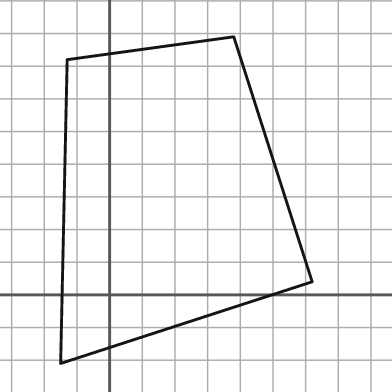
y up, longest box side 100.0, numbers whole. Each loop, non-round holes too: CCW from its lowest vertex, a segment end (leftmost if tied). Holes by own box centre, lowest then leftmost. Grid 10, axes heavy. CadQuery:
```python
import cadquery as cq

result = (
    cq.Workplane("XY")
    .moveTo(-15.0, -21.0)
    .lineTo(62.0, 4.0)
    .lineTo(38.0, 79.0)
    .lineTo(-13.0, 72.0)
    .close()
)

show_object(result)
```